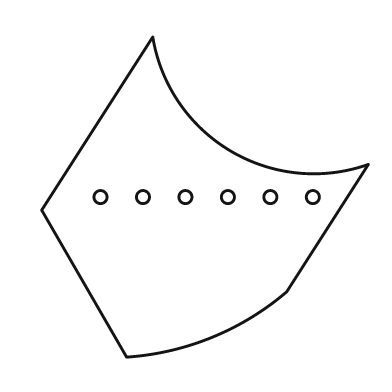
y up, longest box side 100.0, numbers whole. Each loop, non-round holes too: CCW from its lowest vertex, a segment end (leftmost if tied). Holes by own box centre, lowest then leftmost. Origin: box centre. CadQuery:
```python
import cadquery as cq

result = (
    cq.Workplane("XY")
    .moveTo(-24.0, -49.0)
    .threePointArc((2.0, -43.0), (25.0, -29.0))
    .lineTo(50.0, 10.0)
    .threePointArc((8.0, 14.0), (-16.0, 49.0))
    .lineTo(-50.0, -4.0)
    .close()
    .moveTo(-32.0, 0.0)
    .circle(2.0)
    .moveTo(-19.0, 0.0)
    .circle(2.0)
    .moveTo(-6.0, 0.0)
    .circle(2.0)
    .moveTo(7.0, 0.0)
    .circle(2.0)
    .moveTo(20.0, 0.0)
    .circle(2.0)
    .moveTo(33.0, 0.0)
    .circle(2.0)
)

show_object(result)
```